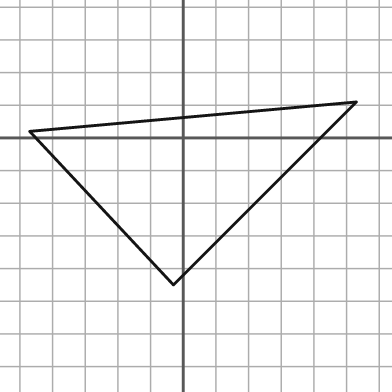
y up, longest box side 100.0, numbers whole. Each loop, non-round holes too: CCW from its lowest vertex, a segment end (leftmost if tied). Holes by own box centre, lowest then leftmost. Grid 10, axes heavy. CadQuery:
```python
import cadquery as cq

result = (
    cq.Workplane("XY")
    .moveTo(-3.0, -45.0)
    .lineTo(53.0, 11.0)
    .lineTo(-47.0, 2.0)
    .close()
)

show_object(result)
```